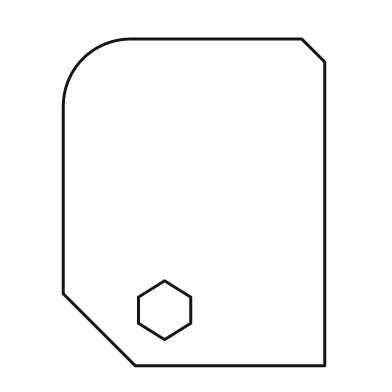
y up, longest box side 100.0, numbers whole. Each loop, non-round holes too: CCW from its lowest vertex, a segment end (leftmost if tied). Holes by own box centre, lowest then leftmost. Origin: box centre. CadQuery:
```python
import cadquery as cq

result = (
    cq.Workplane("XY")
    .moveTo(-18.0, -50.0)
    .lineTo(40.0, -50.0)
    .lineTo(40.0, 43.0)
    .lineTo(33.0, 50.0)
    .lineTo(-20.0, 50.0)
    .threePointArc((-34.0, 44.0), (-40.0, 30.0))
    .lineTo(-40.0, -28.0)
    .close()
    .moveTo(-9.0, -42.0)
    .lineTo(-1.0, -37.0)
    .lineTo(-1.0, -29.0)
    .lineTo(-9.0, -24.0)
    .lineTo(-17.0, -29.0)
    .lineTo(-17.0, -37.0)
    .close()
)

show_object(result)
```